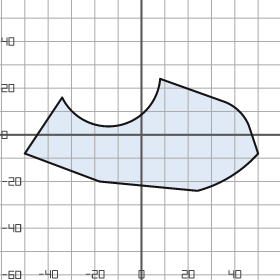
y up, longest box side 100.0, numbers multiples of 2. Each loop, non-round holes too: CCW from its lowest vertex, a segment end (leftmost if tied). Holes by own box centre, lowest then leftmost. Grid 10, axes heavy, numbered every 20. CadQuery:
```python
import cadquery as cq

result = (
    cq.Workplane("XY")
    .moveTo(24.0, -24.0)
    .threePointArc((38.0, -18.0), (50.0, -8.0))
    .lineTo(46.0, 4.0)
    .threePointArc((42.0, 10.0), (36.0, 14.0))
    .lineTo(8.0, 24.0)
    .threePointArc((-10.0, 4.0), (-34.0, 16.0))
    .lineTo(-50.0, -8.0)
    .lineTo(-18.0, -20.0)
    .close()
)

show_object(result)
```